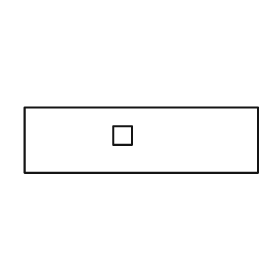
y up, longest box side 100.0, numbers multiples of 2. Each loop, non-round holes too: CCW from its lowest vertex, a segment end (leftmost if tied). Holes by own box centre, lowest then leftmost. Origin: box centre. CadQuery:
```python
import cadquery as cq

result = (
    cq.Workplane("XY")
    .moveTo(-50.0, -14.0)
    .lineTo(50.0, -14.0)
    .lineTo(50.0, 14.0)
    .lineTo(-50.0, 14.0)
    .close()
    .moveTo(-12.0, -2.0)
    .lineTo(-4.0, -2.0)
    .lineTo(-4.0, 6.0)
    .lineTo(-12.0, 6.0)
    .close()
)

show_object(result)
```